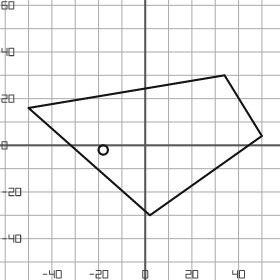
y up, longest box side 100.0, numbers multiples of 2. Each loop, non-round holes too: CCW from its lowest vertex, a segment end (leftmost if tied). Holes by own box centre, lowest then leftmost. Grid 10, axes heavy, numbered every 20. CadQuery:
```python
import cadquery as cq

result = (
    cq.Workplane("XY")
    .moveTo(2.0, -30.0)
    .lineTo(50.0, 4.0)
    .lineTo(34.0, 30.0)
    .lineTo(-50.0, 16.0)
    .close()
    .moveTo(-18.0, -2.0)
    .circle(2.0)
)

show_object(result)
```